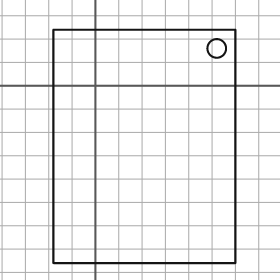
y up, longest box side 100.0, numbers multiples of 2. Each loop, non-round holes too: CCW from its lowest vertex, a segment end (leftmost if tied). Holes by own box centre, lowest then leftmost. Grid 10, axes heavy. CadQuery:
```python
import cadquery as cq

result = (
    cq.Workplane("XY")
    .moveTo(-18.0, -76.0)
    .lineTo(60.0, -76.0)
    .lineTo(60.0, 24.0)
    .lineTo(-18.0, 24.0)
    .close()
    .moveTo(52.0, 16.0)
    .circle(4.0)
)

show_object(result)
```